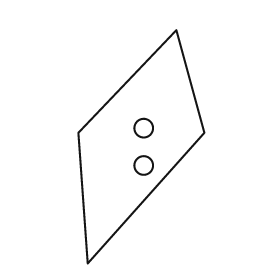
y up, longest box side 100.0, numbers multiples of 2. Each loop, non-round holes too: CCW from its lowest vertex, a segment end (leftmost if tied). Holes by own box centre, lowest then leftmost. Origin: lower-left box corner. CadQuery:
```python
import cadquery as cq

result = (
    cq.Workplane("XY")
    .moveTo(4.0, 0.0)
    .lineTo(54.0, 56.0)
    .lineTo(42.0, 100.0)
    .lineTo(0.0, 56.0)
    .close()
    .moveTo(28.0, 42.0)
    .circle(4.0)
    .moveTo(28.0, 58.0)
    .circle(4.0)
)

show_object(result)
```